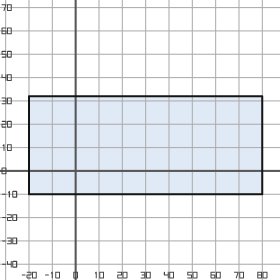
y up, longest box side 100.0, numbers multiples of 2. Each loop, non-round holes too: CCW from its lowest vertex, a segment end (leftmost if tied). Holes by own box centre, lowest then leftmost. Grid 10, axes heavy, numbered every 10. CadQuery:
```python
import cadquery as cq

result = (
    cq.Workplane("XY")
    .moveTo(-20.0, -10.0)
    .lineTo(80.0, -10.0)
    .lineTo(80.0, 32.0)
    .lineTo(-20.0, 32.0)
    .close()
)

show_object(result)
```